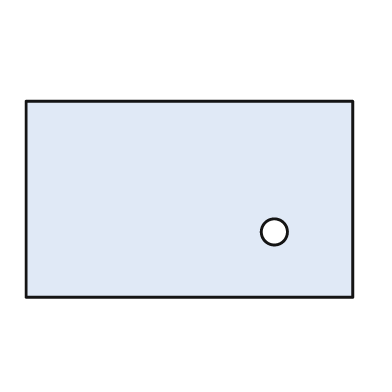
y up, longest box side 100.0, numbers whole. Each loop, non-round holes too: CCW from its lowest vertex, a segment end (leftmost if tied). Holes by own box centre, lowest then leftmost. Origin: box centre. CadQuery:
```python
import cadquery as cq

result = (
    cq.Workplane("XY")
    .moveTo(-50.0, -30.0)
    .lineTo(50.0, -30.0)
    .lineTo(50.0, 30.0)
    .lineTo(-50.0, 30.0)
    .close()
    .moveTo(26.0, -10.0)
    .circle(4.0)
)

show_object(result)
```